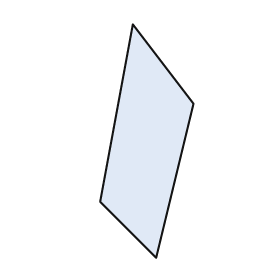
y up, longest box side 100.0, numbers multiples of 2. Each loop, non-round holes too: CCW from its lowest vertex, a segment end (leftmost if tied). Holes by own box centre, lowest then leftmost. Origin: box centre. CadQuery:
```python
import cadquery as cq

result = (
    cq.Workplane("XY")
    .moveTo(4.0, -50.0)
    .lineTo(20.0, 16.0)
    .lineTo(-6.0, 50.0)
    .lineTo(-20.0, -26.0)
    .close()
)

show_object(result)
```